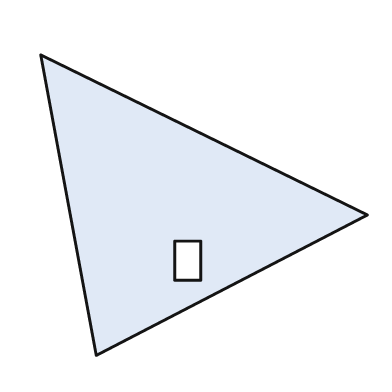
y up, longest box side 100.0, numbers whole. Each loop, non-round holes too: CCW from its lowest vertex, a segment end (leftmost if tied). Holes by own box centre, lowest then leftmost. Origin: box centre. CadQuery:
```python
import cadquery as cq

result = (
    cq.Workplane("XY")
    .moveTo(-33.0, -46.0)
    .lineTo(50.0, -3.0)
    .lineTo(-50.0, 46.0)
    .close()
    .moveTo(-9.0, -23.0)
    .lineTo(-1.0, -23.0)
    .lineTo(-1.0, -11.0)
    .lineTo(-9.0, -11.0)
    .close()
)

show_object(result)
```